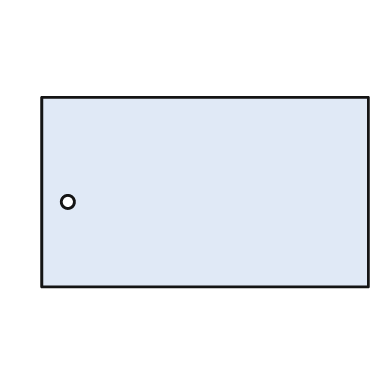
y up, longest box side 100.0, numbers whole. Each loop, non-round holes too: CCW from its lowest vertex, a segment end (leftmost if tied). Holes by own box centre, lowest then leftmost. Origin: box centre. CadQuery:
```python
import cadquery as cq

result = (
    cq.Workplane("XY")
    .moveTo(-50.0, -29.0)
    .lineTo(50.0, -29.0)
    .lineTo(50.0, 29.0)
    .lineTo(-50.0, 29.0)
    .close()
    .moveTo(-42.0, -3.0)
    .circle(2.0)
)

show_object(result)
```